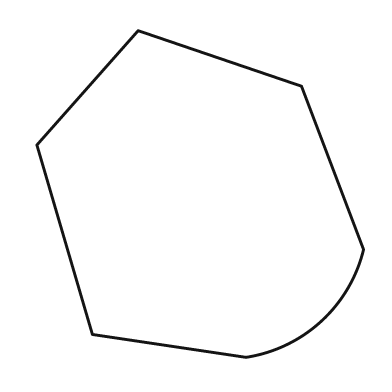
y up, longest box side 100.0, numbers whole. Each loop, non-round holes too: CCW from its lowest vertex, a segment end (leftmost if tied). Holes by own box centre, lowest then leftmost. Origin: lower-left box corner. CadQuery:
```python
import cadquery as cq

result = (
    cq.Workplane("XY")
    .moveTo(64.0, 0.0)
    .threePointArc((87.0, 11.0), (100.0, 33.0))
    .lineTo(81.0, 83.0)
    .lineTo(31.0, 100.0)
    .lineTo(0.0, 65.0)
    .lineTo(17.0, 7.0)
    .close()
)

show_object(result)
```